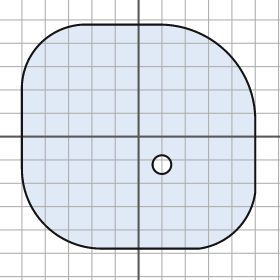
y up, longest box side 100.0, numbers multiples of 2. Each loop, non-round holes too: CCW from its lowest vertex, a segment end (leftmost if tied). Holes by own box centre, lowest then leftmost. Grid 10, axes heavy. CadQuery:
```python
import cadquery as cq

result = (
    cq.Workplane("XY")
    .moveTo(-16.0, -48.0)
    .lineTo(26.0, -48.0)
    .threePointArc((42.0, -40.0), (50.0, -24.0))
    .lineTo(50.0, 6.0)
    .threePointArc((38.0, 36.0), (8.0, 48.0))
    .lineTo(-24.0, 48.0)
    .threePointArc((-42.0, 40.0), (-50.0, 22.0))
    .lineTo(-50.0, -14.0)
    .threePointArc((-40.0, -38.0), (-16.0, -48.0))
    .close()
    .moveTo(10.0, -12.0)
    .circle(4.0)
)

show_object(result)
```